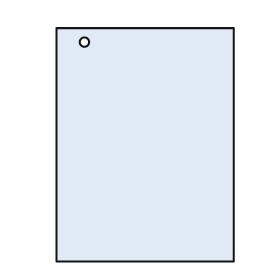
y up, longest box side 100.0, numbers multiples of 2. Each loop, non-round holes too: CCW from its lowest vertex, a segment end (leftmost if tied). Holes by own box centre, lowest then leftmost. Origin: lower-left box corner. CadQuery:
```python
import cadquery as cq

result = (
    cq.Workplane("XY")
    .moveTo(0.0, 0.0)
    .lineTo(76.0, 0.0)
    .lineTo(76.0, 100.0)
    .lineTo(0.0, 100.0)
    .close()
    .moveTo(12.0, 94.0)
    .circle(2.0)
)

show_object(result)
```